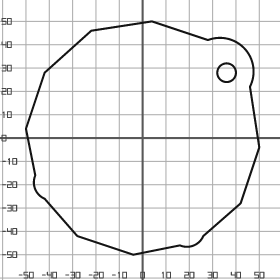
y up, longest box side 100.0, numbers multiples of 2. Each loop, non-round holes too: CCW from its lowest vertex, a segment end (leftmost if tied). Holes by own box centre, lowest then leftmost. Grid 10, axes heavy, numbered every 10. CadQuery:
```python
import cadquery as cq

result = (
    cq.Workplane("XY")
    .moveTo(-4.0, -50.0)
    .lineTo(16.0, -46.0)
    .threePointArc((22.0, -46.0), (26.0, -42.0))
    .lineTo(42.0, -28.0)
    .lineTo(50.0, -4.0)
    .lineTo(46.0, 22.0)
    .threePointArc((44.0, 38.0), (28.0, 42.0))
    .lineTo(4.0, 50.0)
    .lineTo(-22.0, 46.0)
    .lineTo(-42.0, 28.0)
    .lineTo(-50.0, 4.0)
    .lineTo(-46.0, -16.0)
    .threePointArc((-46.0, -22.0), (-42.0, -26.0))
    .lineTo(-28.0, -42.0)
    .close()
    .moveTo(36.0, 28.0)
    .circle(4.0)
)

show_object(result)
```